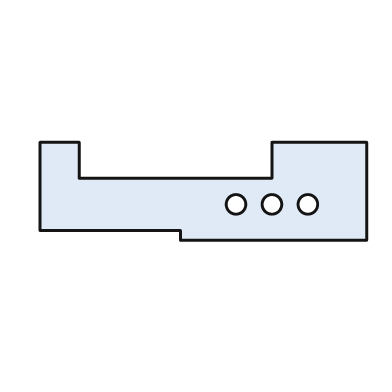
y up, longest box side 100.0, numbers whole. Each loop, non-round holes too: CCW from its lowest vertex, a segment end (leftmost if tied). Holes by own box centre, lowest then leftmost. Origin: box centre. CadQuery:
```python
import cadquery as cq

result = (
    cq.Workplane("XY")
    .moveTo(-7.0, -15.0)
    .lineTo(50.0, -15.0)
    .lineTo(50.0, 15.0)
    .lineTo(21.0, 15.0)
    .lineTo(21.0, 4.0)
    .lineTo(-38.0, 4.0)
    .lineTo(-38.0, 15.0)
    .lineTo(-50.0, 15.0)
    .lineTo(-50.0, -12.0)
    .lineTo(-7.0, -12.0)
    .close()
    .moveTo(10.0, -4.0)
    .circle(3.0)
    .moveTo(21.0, -4.0)
    .circle(3.0)
    .moveTo(32.0, -4.0)
    .circle(3.0)
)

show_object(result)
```